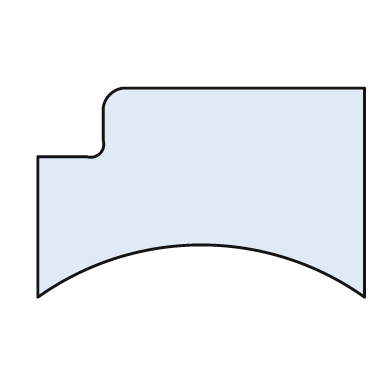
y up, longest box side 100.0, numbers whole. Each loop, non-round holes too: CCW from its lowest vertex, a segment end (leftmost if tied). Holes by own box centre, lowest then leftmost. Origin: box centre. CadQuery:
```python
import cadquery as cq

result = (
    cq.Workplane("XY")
    .moveTo(-50.0, -32.0)
    .threePointArc((0.0, -16.0), (50.0, -32.0))
    .lineTo(50.0, 32.0)
    .lineTo(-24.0, 32.0)
    .threePointArc((-28.0, 30.0), (-30.0, 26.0))
    .lineTo(-30.0, 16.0)
    .threePointArc((-31.0, 12.0), (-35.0, 11.0))
    .lineTo(-50.0, 11.0)
    .close()
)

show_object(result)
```